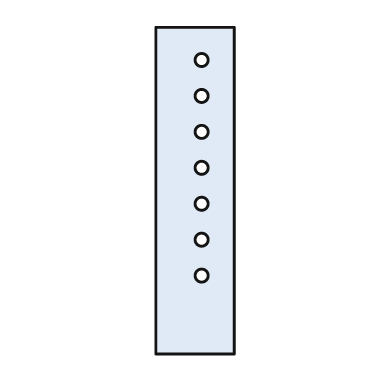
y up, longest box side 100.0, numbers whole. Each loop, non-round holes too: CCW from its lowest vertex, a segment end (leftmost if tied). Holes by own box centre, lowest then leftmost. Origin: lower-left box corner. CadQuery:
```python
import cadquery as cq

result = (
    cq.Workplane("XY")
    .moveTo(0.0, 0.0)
    .lineTo(24.0, 0.0)
    .lineTo(24.0, 100.0)
    .lineTo(0.0, 100.0)
    .close()
    .moveTo(14.0, 24.0)
    .circle(2.0)
    .moveTo(14.0, 35.0)
    .circle(2.0)
    .moveTo(14.0, 46.0)
    .circle(2.0)
    .moveTo(14.0, 57.0)
    .circle(2.0)
    .moveTo(14.0, 68.0)
    .circle(2.0)
    .moveTo(14.0, 79.0)
    .circle(2.0)
    .moveTo(14.0, 90.0)
    .circle(2.0)
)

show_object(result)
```